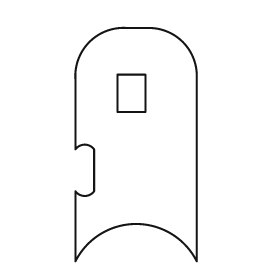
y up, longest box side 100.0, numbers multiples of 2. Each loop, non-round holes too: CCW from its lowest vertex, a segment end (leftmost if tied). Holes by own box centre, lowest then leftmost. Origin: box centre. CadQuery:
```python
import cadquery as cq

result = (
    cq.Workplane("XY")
    .moveTo(-26.0, -50.0)
    .threePointArc((0.0, -34.0), (26.0, -50.0))
    .lineTo(26.0, 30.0)
    .threePointArc((20.0, 44.0), (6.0, 50.0))
    .lineTo(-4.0, 50.0)
    .threePointArc((-20.0, 44.0), (-26.0, 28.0))
    .lineTo(-26.0, -2.0)
    .threePointArc((-22.0, 0.0), (-18.0, -2.0))
    .lineTo(-18.0, -20.0)
    .threePointArc((-22.0, -22.0), (-26.0, -20.0))
    .close()
    .moveTo(-8.0, 14.0)
    .lineTo(4.0, 14.0)
    .lineTo(4.0, 30.0)
    .lineTo(-8.0, 30.0)
    .close()
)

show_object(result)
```